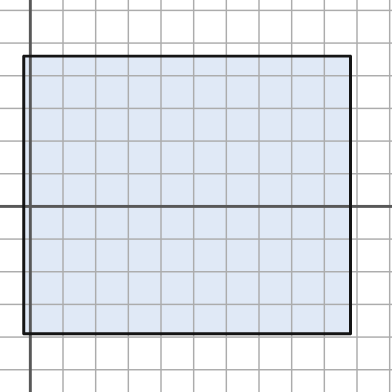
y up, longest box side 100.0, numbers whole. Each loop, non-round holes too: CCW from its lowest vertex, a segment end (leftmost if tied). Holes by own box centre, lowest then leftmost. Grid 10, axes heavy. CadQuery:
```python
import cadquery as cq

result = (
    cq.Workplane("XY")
    .moveTo(-2.0, -39.0)
    .lineTo(98.0, -39.0)
    .lineTo(98.0, 46.0)
    .lineTo(-2.0, 46.0)
    .close()
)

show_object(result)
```